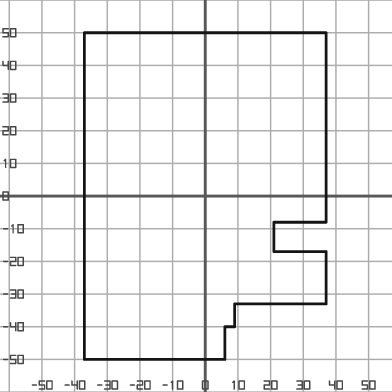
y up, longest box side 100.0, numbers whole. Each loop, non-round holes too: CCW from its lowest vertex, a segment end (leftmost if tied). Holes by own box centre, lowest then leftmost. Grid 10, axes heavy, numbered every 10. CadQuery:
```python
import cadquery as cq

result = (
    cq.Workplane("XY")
    .moveTo(-37.0, -50.0)
    .lineTo(6.0, -50.0)
    .lineTo(6.0, -40.0)
    .lineTo(9.0, -40.0)
    .lineTo(9.0, -33.0)
    .lineTo(37.0, -33.0)
    .lineTo(37.0, -17.0)
    .lineTo(21.0, -17.0)
    .lineTo(21.0, -8.0)
    .lineTo(37.0, -8.0)
    .lineTo(37.0, 50.0)
    .lineTo(-37.0, 50.0)
    .close()
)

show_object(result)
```